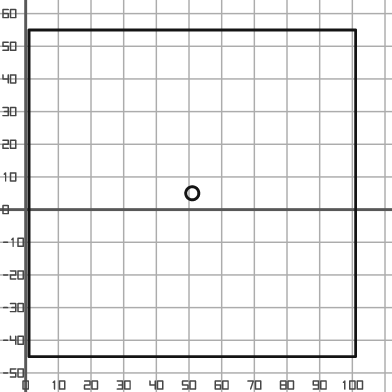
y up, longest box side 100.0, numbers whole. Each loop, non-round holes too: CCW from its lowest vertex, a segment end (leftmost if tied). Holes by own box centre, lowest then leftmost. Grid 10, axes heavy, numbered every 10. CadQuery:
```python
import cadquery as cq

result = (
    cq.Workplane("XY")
    .moveTo(1.0, -45.0)
    .lineTo(101.0, -45.0)
    .lineTo(101.0, 55.0)
    .lineTo(1.0, 55.0)
    .close()
    .moveTo(51.0, 5.0)
    .circle(2.0)
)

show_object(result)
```